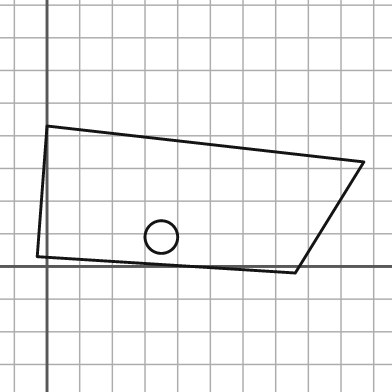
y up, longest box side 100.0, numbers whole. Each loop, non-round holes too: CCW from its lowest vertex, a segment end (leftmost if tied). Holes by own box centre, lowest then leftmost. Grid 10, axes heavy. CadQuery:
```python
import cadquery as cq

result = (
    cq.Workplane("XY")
    .moveTo(76.0, -2.0)
    .lineTo(97.0, 32.0)
    .lineTo(0.0, 43.0)
    .lineTo(-3.0, 3.0)
    .close()
    .moveTo(35.0, 9.0)
    .circle(5.0)
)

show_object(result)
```